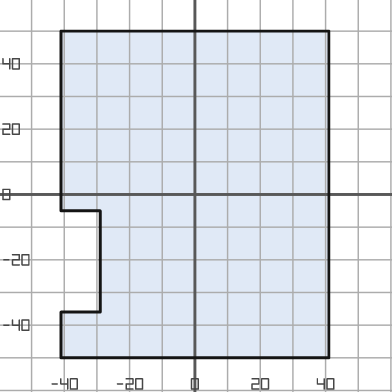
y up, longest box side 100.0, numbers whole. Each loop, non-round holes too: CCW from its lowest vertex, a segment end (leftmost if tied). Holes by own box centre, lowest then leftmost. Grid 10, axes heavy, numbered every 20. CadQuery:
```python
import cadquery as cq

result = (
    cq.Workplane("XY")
    .moveTo(-41.0, -50.0)
    .lineTo(41.0, -50.0)
    .lineTo(41.0, 50.0)
    .lineTo(-41.0, 50.0)
    .lineTo(-41.0, -5.0)
    .lineTo(-29.0, -5.0)
    .lineTo(-29.0, -36.0)
    .lineTo(-41.0, -36.0)
    .close()
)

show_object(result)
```